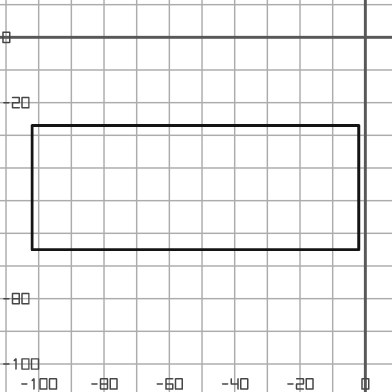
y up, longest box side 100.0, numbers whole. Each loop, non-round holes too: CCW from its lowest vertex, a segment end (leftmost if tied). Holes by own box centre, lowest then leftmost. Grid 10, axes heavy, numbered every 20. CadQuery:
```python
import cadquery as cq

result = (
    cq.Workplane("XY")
    .moveTo(-102.0, -65.0)
    .lineTo(-2.0, -65.0)
    .lineTo(-2.0, -27.0)
    .lineTo(-102.0, -27.0)
    .close()
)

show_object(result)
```